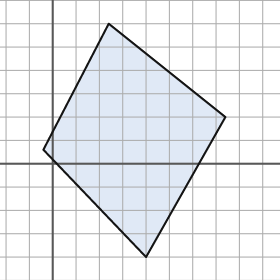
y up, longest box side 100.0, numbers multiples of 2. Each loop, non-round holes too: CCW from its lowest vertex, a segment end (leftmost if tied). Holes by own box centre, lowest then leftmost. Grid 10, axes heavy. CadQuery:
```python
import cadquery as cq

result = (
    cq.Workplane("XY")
    .moveTo(40.0, -40.0)
    .lineTo(74.0, 20.0)
    .lineTo(24.0, 60.0)
    .lineTo(-4.0, 6.0)
    .close()
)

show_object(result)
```